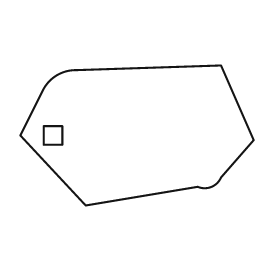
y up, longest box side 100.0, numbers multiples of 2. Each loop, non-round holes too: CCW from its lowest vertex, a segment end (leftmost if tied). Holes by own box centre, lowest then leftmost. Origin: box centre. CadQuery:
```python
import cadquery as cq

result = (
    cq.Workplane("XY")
    .moveTo(-22.0, -30.0)
    .lineTo(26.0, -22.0)
    .threePointArc((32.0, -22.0), (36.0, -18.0))
    .lineTo(50.0, -2.0)
    .lineTo(36.0, 30.0)
    .lineTo(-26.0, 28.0)
    .threePointArc((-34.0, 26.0), (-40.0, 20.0))
    .lineTo(-50.0, 0.0)
    .close()
    .moveTo(-40.0, -4.0)
    .lineTo(-32.0, -4.0)
    .lineTo(-32.0, 4.0)
    .lineTo(-40.0, 4.0)
    .close()
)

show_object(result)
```